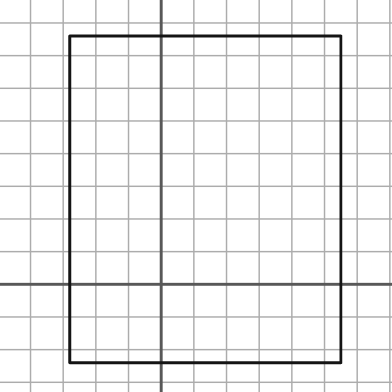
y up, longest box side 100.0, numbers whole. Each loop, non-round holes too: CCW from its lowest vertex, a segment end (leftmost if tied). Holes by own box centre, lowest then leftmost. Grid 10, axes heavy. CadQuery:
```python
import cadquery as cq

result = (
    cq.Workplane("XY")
    .moveTo(-28.0, -24.0)
    .lineTo(55.0, -24.0)
    .lineTo(55.0, 76.0)
    .lineTo(-28.0, 76.0)
    .close()
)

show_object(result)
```